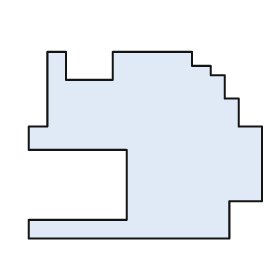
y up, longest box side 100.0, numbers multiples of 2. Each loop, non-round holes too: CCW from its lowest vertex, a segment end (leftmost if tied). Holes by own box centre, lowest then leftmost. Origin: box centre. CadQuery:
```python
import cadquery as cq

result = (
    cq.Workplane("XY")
    .moveTo(-50.0, -40.0)
    .lineTo(36.0, -40.0)
    .lineTo(36.0, -24.0)
    .lineTo(50.0, -24.0)
    .lineTo(50.0, 8.0)
    .lineTo(40.0, 8.0)
    .lineTo(40.0, 20.0)
    .lineTo(34.0, 20.0)
    .lineTo(34.0, 30.0)
    .lineTo(28.0, 30.0)
    .lineTo(28.0, 34.0)
    .lineTo(20.0, 34.0)
    .lineTo(20.0, 40.0)
    .lineTo(-14.0, 40.0)
    .lineTo(-14.0, 28.0)
    .lineTo(-34.0, 28.0)
    .lineTo(-34.0, 40.0)
    .lineTo(-42.0, 40.0)
    .lineTo(-42.0, 8.0)
    .lineTo(-50.0, 8.0)
    .lineTo(-50.0, -2.0)
    .lineTo(-8.0, -2.0)
    .lineTo(-8.0, -32.0)
    .lineTo(-50.0, -32.0)
    .close()
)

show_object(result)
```